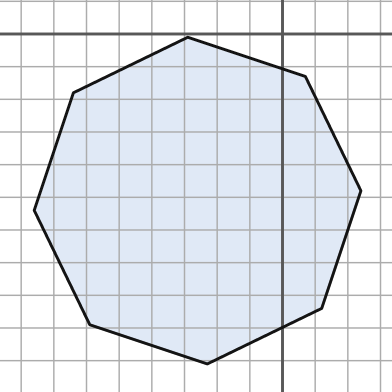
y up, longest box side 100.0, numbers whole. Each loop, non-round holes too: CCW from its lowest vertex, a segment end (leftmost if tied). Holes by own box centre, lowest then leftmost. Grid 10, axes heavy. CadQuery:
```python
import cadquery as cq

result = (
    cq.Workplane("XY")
    .moveTo(-23.0, -101.0)
    .lineTo(12.0, -84.0)
    .lineTo(24.0, -48.0)
    .lineTo(7.0, -13.0)
    .lineTo(-29.0, -1.0)
    .lineTo(-64.0, -18.0)
    .lineTo(-76.0, -54.0)
    .lineTo(-59.0, -89.0)
    .close()
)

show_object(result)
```